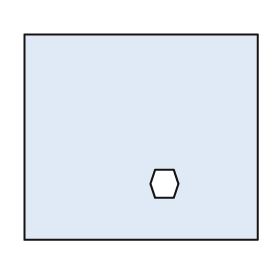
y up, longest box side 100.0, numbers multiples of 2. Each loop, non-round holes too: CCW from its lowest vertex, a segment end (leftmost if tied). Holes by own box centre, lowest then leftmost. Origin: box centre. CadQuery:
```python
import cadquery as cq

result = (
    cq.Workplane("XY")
    .moveTo(-50.0, -44.0)
    .lineTo(50.0, -44.0)
    .lineTo(50.0, 44.0)
    .lineTo(-50.0, 44.0)
    .close()
    .moveTo(6.0, -26.0)
    .lineTo(14.0, -26.0)
    .lineTo(16.0, -20.0)
    .lineTo(14.0, -14.0)
    .lineTo(6.0, -14.0)
    .lineTo(4.0, -20.0)
    .close()
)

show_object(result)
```